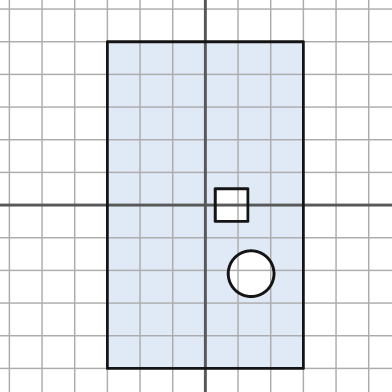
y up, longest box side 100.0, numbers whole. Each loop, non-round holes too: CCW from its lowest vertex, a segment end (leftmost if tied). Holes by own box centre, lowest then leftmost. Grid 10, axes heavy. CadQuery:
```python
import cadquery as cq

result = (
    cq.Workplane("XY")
    .moveTo(-30.0, -50.0)
    .lineTo(30.0, -50.0)
    .lineTo(30.0, 50.0)
    .lineTo(-30.0, 50.0)
    .close()
    .moveTo(14.0, -21.0)
    .circle(7.0)
    .moveTo(3.0, -5.0)
    .lineTo(13.0, -5.0)
    .lineTo(13.0, 5.0)
    .lineTo(3.0, 5.0)
    .close()
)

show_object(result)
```